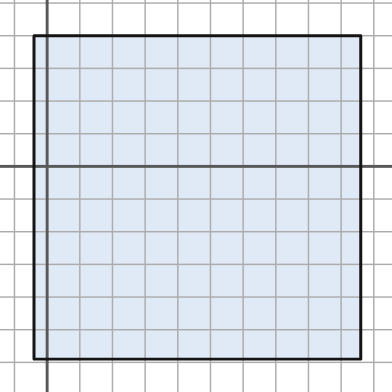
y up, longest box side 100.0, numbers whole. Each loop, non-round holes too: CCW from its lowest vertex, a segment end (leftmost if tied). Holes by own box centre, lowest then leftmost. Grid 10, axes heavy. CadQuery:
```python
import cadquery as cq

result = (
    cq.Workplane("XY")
    .moveTo(-4.0, -59.0)
    .lineTo(96.0, -59.0)
    .lineTo(96.0, 40.0)
    .lineTo(-4.0, 40.0)
    .close()
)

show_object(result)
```